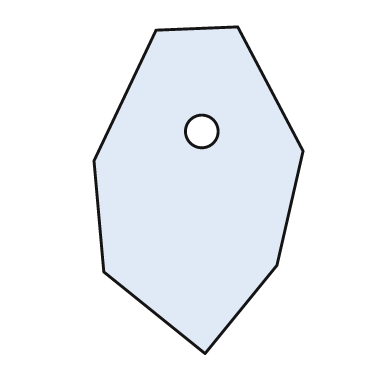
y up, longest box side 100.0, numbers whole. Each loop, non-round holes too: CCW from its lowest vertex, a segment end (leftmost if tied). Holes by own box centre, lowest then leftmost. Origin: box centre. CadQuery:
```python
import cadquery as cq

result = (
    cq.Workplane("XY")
    .moveTo(2.0, -50.0)
    .lineTo(24.0, -23.0)
    .lineTo(32.0, 12.0)
    .lineTo(12.0, 50.0)
    .lineTo(-13.0, 49.0)
    .lineTo(-32.0, 9.0)
    .lineTo(-29.0, -25.0)
    .close()
    .moveTo(1.0, 18.0)
    .circle(5.0)
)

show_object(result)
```